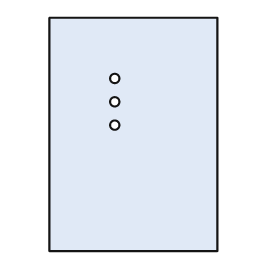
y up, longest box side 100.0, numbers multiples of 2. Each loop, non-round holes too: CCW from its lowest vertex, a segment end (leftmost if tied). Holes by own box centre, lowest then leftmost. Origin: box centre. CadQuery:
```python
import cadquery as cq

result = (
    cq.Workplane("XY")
    .moveTo(-36.0, -50.0)
    .lineTo(36.0, -50.0)
    .lineTo(36.0, 50.0)
    .lineTo(-36.0, 50.0)
    .close()
    .moveTo(-8.0, 4.0)
    .circle(2.0)
    .moveTo(-8.0, 14.0)
    .circle(2.0)
    .moveTo(-8.0, 24.0)
    .circle(2.0)
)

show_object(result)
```